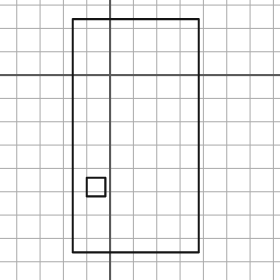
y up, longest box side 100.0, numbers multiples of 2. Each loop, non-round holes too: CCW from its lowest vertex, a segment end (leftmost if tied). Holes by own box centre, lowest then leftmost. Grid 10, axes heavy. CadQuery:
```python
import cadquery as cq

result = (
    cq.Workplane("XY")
    .moveTo(-16.0, -76.0)
    .lineTo(38.0, -76.0)
    .lineTo(38.0, 24.0)
    .lineTo(-16.0, 24.0)
    .close()
    .moveTo(-10.0, -52.0)
    .lineTo(-2.0, -52.0)
    .lineTo(-2.0, -44.0)
    .lineTo(-10.0, -44.0)
    .close()
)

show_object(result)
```